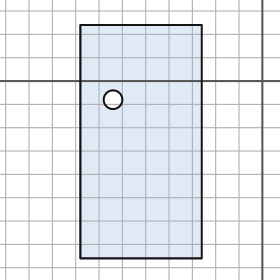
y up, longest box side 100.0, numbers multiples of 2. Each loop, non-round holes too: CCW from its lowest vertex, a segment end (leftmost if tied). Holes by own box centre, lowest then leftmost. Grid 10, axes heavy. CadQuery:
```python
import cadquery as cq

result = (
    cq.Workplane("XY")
    .moveTo(-78.0, -76.0)
    .lineTo(-26.0, -76.0)
    .lineTo(-26.0, 24.0)
    .lineTo(-78.0, 24.0)
    .close()
    .moveTo(-64.0, -8.0)
    .circle(4.0)
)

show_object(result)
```